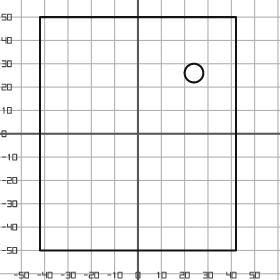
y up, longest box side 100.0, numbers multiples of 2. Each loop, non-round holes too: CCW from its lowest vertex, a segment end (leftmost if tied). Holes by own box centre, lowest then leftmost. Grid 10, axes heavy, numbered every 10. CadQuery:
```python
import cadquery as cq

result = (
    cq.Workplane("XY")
    .moveTo(-42.0, -50.0)
    .lineTo(42.0, -50.0)
    .lineTo(42.0, 50.0)
    .lineTo(-42.0, 50.0)
    .close()
    .moveTo(24.0, 26.0)
    .circle(4.0)
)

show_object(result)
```